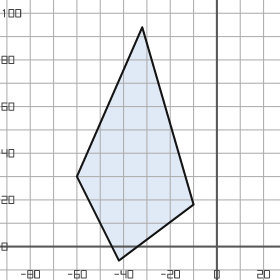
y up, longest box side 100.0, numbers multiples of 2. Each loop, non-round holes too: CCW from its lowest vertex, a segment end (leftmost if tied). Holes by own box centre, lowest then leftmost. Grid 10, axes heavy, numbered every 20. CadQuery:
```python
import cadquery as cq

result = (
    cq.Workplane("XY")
    .moveTo(-42.0, -6.0)
    .lineTo(-10.0, 18.0)
    .lineTo(-32.0, 94.0)
    .lineTo(-60.0, 30.0)
    .close()
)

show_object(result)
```